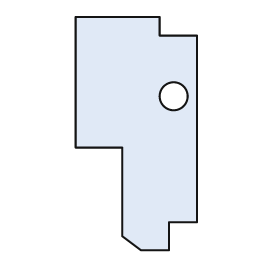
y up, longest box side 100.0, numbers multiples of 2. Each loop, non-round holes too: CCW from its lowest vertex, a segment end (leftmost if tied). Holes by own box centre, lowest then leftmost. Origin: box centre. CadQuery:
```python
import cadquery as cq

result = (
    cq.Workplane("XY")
    .moveTo(2.0, -50.0)
    .lineTo(14.0, -50.0)
    .lineTo(14.0, -38.0)
    .lineTo(26.0, -38.0)
    .lineTo(26.0, 42.0)
    .lineTo(10.0, 42.0)
    .lineTo(10.0, 50.0)
    .lineTo(-26.0, 50.0)
    .lineTo(-26.0, -6.0)
    .lineTo(-6.0, -6.0)
    .lineTo(-6.0, -44.0)
    .close()
    .moveTo(16.0, 16.0)
    .circle(6.0)
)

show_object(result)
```